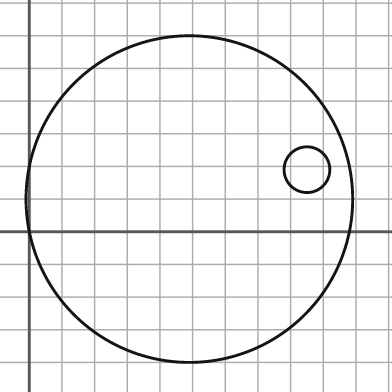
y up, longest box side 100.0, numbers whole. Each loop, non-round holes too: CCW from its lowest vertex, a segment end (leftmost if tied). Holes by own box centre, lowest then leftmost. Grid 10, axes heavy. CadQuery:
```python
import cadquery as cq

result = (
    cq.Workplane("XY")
    .moveTo(49.0, 10.0)
    .circle(50.0)
    .moveTo(85.0, 19.0)
    .circle(7.0)
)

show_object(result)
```